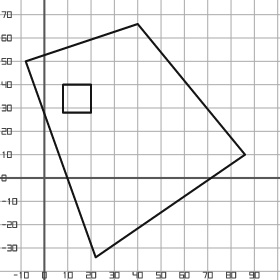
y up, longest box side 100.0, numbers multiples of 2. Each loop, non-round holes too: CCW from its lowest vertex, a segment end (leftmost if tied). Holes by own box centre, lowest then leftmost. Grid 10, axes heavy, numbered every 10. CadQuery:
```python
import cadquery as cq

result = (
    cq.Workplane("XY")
    .moveTo(22.0, -34.0)
    .lineTo(86.0, 10.0)
    .lineTo(40.0, 66.0)
    .lineTo(-8.0, 50.0)
    .close()
    .moveTo(8.0, 28.0)
    .lineTo(20.0, 28.0)
    .lineTo(20.0, 40.0)
    .lineTo(8.0, 40.0)
    .close()
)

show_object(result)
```